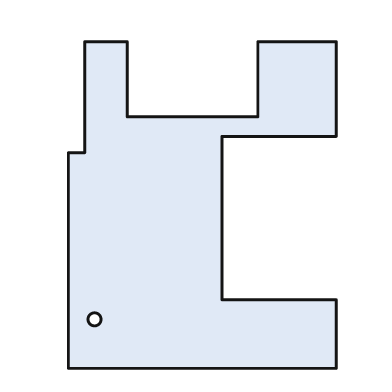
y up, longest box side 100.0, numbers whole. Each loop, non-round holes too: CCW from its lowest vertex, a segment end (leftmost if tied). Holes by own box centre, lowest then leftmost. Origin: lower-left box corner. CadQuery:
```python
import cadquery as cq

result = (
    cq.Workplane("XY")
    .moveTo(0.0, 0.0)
    .lineTo(82.0, 0.0)
    .lineTo(82.0, 21.0)
    .lineTo(47.0, 21.0)
    .lineTo(47.0, 71.0)
    .lineTo(82.0, 71.0)
    .lineTo(82.0, 100.0)
    .lineTo(58.0, 100.0)
    .lineTo(58.0, 77.0)
    .lineTo(18.0, 77.0)
    .lineTo(18.0, 100.0)
    .lineTo(5.0, 100.0)
    .lineTo(5.0, 66.0)
    .lineTo(0.0, 66.0)
    .close()
    .moveTo(8.0, 15.0)
    .circle(2.0)
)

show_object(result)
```